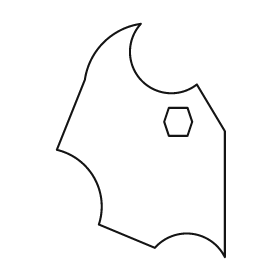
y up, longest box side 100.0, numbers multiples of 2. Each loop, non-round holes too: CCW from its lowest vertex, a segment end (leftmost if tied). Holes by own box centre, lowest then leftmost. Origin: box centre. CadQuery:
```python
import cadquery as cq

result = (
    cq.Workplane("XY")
    .moveTo(36.0, -50.0)
    .lineTo(36.0, 4.0)
    .lineTo(24.0, 24.0)
    .threePointArc((0.0, 26.0), (0.0, 50.0))
    .threePointArc((-16.0, 42.0), (-24.0, 26.0))
    .lineTo(-36.0, -4.0)
    .threePointArc((-20.0, -16.0), (-18.0, -36.0))
    .lineTo(6.0, -46.0)
    .threePointArc((22.0, -40.0), (36.0, -50.0))
    .close()
    .moveTo(12.0, 2.0)
    .lineTo(20.0, 2.0)
    .lineTo(22.0, 8.0)
    .lineTo(20.0, 14.0)
    .lineTo(12.0, 14.0)
    .lineTo(10.0, 8.0)
    .close()
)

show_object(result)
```